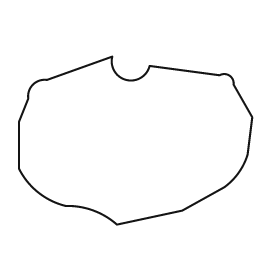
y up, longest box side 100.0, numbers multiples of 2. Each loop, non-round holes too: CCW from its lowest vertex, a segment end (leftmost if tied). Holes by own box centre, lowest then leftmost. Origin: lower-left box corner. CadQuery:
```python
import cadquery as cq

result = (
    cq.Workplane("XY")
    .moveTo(42.0, 0.0)
    .lineTo(70.0, 6.0)
    .lineTo(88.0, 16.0)
    .threePointArc((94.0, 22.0), (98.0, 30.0))
    .lineTo(100.0, 46.0)
    .lineTo(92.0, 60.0)
    .threePointArc((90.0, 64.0), (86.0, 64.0))
    .lineTo(56.0, 68.0)
    .threePointArc((46.0, 62.0), (40.0, 72.0))
    .lineTo(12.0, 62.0)
    .threePointArc((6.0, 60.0), (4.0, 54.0))
    .lineTo(0.0, 44.0)
    .lineTo(0.0, 24.0)
    .threePointArc((8.0, 14.0), (20.0, 8.0))
    .threePointArc((32.0, 6.0), (42.0, 0.0))
    .close()
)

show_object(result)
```